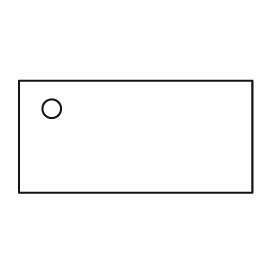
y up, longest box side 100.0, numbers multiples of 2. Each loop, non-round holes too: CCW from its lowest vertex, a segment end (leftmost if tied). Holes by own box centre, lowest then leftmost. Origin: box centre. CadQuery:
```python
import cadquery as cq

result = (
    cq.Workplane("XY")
    .moveTo(-50.0, -24.0)
    .lineTo(50.0, -24.0)
    .lineTo(50.0, 24.0)
    .lineTo(-50.0, 24.0)
    .close()
    .moveTo(-36.0, 12.0)
    .circle(4.0)
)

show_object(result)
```